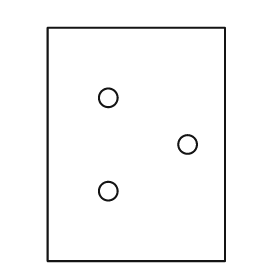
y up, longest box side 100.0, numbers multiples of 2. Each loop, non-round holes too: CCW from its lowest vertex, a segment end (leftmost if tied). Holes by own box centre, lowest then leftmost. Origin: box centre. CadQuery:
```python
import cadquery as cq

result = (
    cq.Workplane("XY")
    .moveTo(-38.0, -50.0)
    .lineTo(38.0, -50.0)
    .lineTo(38.0, 50.0)
    .lineTo(-38.0, 50.0)
    .close()
    .moveTo(-12.0, -20.0)
    .circle(4.0)
    .moveTo(22.0, 0.0)
    .circle(4.0)
    .moveTo(-12.0, 20.0)
    .circle(4.0)
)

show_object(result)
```